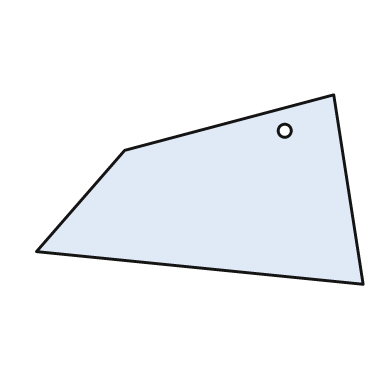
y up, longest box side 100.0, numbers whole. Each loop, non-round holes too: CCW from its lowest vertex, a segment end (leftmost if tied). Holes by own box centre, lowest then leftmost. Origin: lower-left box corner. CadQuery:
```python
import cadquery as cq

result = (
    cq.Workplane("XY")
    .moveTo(100.0, 0.0)
    .lineTo(91.0, 58.0)
    .lineTo(27.0, 41.0)
    .lineTo(0.0, 10.0)
    .close()
    .moveTo(76.0, 47.0)
    .circle(2.0)
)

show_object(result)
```